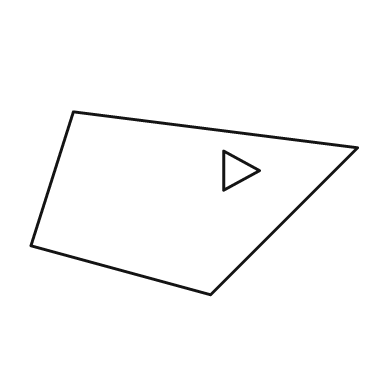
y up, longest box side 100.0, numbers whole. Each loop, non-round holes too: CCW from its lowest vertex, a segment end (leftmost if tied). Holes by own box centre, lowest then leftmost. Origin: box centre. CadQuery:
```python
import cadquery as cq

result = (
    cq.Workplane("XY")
    .moveTo(5.0, -28.0)
    .lineTo(50.0, 17.0)
    .lineTo(-37.0, 28.0)
    .lineTo(-50.0, -13.0)
    .close()
    .moveTo(9.0, 4.0)
    .lineTo(20.0, 10.0)
    .lineTo(9.0, 16.0)
    .close()
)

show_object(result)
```